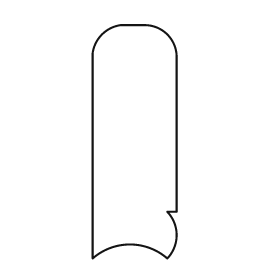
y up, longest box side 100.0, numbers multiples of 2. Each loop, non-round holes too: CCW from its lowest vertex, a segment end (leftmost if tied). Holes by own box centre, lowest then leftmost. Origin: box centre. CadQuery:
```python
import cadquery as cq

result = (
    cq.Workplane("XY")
    .moveTo(-18.0, -50.0)
    .threePointArc((-2.0, -44.0), (14.0, -50.0))
    .threePointArc((18.0, -40.0), (14.0, -30.0))
    .lineTo(18.0, -30.0)
    .lineTo(18.0, 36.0)
    .threePointArc((14.0, 46.0), (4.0, 50.0))
    .lineTo(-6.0, 50.0)
    .threePointArc((-14.0, 46.0), (-18.0, 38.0))
    .close()
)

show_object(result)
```